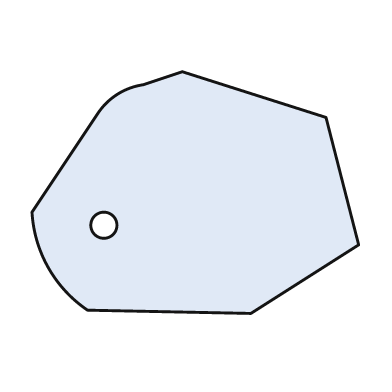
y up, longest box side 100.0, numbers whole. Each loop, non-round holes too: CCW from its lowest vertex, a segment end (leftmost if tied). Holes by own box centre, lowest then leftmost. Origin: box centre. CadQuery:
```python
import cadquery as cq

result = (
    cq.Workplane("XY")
    .moveTo(17.0, -37.0)
    .lineTo(50.0, -16.0)
    .lineTo(40.0, 23.0)
    .lineTo(-4.0, 37.0)
    .lineTo(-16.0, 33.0)
    .threePointArc((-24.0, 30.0), (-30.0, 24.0))
    .lineTo(-50.0, -6.0)
    .threePointArc((-45.0, -23.0), (-33.0, -36.0))
    .close()
    .moveTo(-28.0, -10.0)
    .circle(4.0)
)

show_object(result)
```